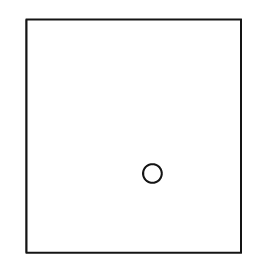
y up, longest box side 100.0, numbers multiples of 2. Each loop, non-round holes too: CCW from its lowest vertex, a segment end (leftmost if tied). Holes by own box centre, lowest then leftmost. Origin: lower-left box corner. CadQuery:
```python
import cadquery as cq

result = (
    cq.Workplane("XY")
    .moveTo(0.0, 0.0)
    .lineTo(92.0, 0.0)
    .lineTo(92.0, 100.0)
    .lineTo(0.0, 100.0)
    .close()
    .moveTo(54.0, 34.0)
    .circle(4.0)
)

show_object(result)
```